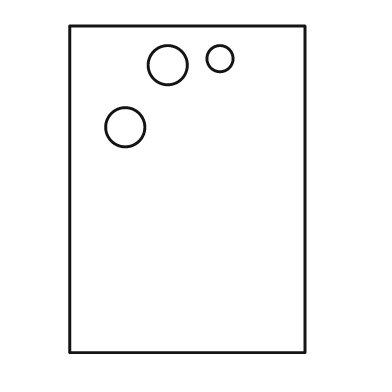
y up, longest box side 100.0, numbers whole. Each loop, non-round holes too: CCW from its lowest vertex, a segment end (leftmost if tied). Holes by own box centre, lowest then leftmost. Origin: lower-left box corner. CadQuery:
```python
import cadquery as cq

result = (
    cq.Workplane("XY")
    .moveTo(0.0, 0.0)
    .lineTo(72.0, 0.0)
    .lineTo(72.0, 100.0)
    .lineTo(0.0, 100.0)
    .close()
    .moveTo(17.0, 69.0)
    .circle(6.0)
    .moveTo(30.0, 88.0)
    .circle(6.0)
    .moveTo(46.0, 90.0)
    .circle(4.0)
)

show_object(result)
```